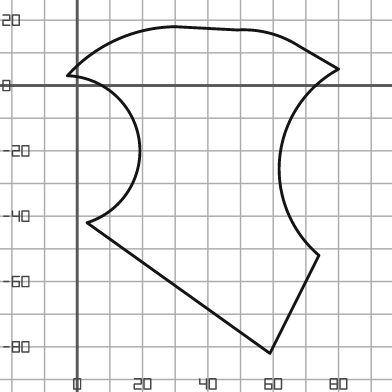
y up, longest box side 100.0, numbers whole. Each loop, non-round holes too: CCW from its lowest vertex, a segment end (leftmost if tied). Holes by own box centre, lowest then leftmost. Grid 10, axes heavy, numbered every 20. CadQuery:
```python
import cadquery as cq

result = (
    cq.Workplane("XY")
    .moveTo(59.0, -82.0)
    .lineTo(74.0, -52.0)
    .threePointArc((62.0, -22.0), (80.0, 5.0))
    .lineTo(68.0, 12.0)
    .threePointArc((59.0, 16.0), (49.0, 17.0))
    .lineTo(30.0, 18.0)
    .threePointArc((12.0, 14.0), (-3.0, 3.0))
    .threePointArc((19.0, -17.0), (3.0, -42.0))
    .close()
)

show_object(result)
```